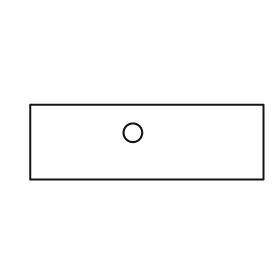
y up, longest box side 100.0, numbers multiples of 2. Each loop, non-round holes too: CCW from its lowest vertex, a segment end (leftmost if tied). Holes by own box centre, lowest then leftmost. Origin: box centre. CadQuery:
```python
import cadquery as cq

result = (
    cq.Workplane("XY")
    .moveTo(-50.0, -16.0)
    .lineTo(50.0, -16.0)
    .lineTo(50.0, 16.0)
    .lineTo(-50.0, 16.0)
    .close()
    .moveTo(-6.0, 4.0)
    .circle(4.0)
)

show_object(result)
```